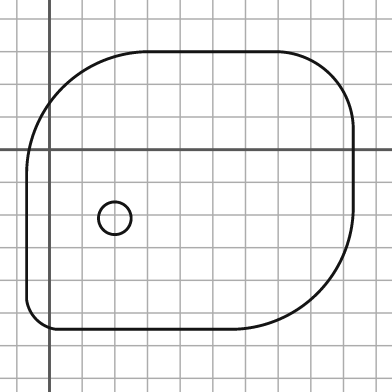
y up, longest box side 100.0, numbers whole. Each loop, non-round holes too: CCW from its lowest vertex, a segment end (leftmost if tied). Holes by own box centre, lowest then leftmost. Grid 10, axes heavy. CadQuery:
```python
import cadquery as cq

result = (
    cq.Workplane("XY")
    .moveTo(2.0, -55.0)
    .lineTo(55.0, -55.0)
    .threePointArc((82.0, -44.0), (93.0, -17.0))
    .lineTo(93.0, 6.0)
    .threePointArc((86.0, 23.0), (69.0, 30.0))
    .lineTo(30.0, 30.0)
    .threePointArc((4.0, 19.0), (-7.0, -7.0))
    .lineTo(-7.0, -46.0)
    .threePointArc((-4.0, -52.0), (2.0, -55.0))
    .close()
    .moveTo(20.0, -21.0)
    .circle(5.0)
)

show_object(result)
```